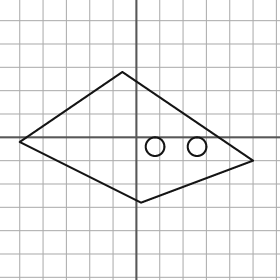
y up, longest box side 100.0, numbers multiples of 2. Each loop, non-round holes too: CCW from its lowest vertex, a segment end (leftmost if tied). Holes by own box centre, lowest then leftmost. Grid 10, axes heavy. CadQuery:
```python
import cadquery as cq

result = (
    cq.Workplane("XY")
    .moveTo(2.0, -28.0)
    .lineTo(50.0, -10.0)
    .lineTo(-6.0, 28.0)
    .lineTo(-50.0, -2.0)
    .close()
    .moveTo(8.0, -4.0)
    .circle(4.0)
    .moveTo(26.0, -4.0)
    .circle(4.0)
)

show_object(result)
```